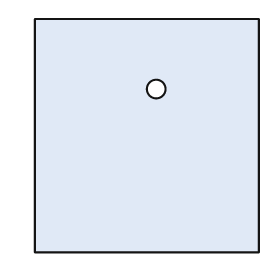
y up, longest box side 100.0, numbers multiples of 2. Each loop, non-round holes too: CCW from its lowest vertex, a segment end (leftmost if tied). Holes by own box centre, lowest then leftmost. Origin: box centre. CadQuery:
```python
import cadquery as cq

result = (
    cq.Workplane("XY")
    .moveTo(-48.0, -50.0)
    .lineTo(48.0, -50.0)
    .lineTo(48.0, 50.0)
    .lineTo(-48.0, 50.0)
    .close()
    .moveTo(4.0, 20.0)
    .circle(4.0)
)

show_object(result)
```